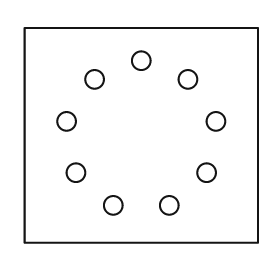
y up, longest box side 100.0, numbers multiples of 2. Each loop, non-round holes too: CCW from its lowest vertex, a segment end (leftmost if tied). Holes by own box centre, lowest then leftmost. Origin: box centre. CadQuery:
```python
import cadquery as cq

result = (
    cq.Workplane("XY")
    .moveTo(-50.0, -46.0)
    .lineTo(50.0, -46.0)
    .lineTo(50.0, 46.0)
    .lineTo(-50.0, 46.0)
    .close()
    .moveTo(-12.0, -30.0)
    .circle(4.0)
    .moveTo(12.0, -30.0)
    .circle(4.0)
    .moveTo(-28.0, -16.0)
    .circle(4.0)
    .moveTo(28.0, -16.0)
    .circle(4.0)
    .moveTo(-32.0, 6.0)
    .circle(4.0)
    .moveTo(32.0, 6.0)
    .circle(4.0)
    .moveTo(-20.0, 24.0)
    .circle(4.0)
    .moveTo(20.0, 24.0)
    .circle(4.0)
    .moveTo(0.0, 32.0)
    .circle(4.0)
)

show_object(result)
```